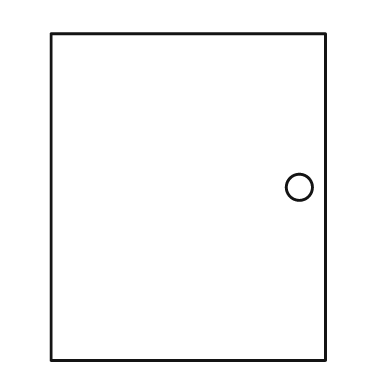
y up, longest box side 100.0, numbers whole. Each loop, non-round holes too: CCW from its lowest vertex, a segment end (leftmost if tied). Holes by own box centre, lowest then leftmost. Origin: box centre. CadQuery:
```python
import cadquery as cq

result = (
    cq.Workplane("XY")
    .moveTo(-42.0, -50.0)
    .lineTo(42.0, -50.0)
    .lineTo(42.0, 50.0)
    .lineTo(-42.0, 50.0)
    .close()
    .moveTo(34.0, 3.0)
    .circle(4.0)
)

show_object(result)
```